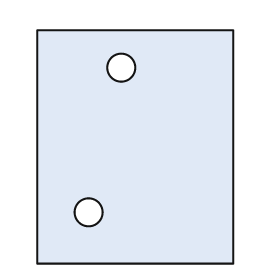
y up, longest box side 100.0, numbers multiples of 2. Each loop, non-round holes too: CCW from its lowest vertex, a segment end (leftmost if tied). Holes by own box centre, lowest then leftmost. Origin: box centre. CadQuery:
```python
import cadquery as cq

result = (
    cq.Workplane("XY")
    .moveTo(-42.0, -50.0)
    .lineTo(42.0, -50.0)
    .lineTo(42.0, 50.0)
    .lineTo(-42.0, 50.0)
    .close()
    .moveTo(-20.0, -28.0)
    .circle(6.0)
    .moveTo(-6.0, 34.0)
    .circle(6.0)
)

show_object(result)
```